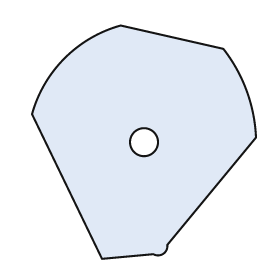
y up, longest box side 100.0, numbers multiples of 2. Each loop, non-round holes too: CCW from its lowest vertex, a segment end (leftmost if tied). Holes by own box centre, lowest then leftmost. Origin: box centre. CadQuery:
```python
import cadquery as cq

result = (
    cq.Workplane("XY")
    .moveTo(-18.0, -50.0)
    .lineTo(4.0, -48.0)
    .threePointArc((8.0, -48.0), (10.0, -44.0))
    .lineTo(48.0, 2.0)
    .threePointArc((44.0, 22.0), (34.0, 40.0))
    .lineTo(-10.0, 50.0)
    .threePointArc((-34.0, 36.0), (-48.0, 12.0))
    .close()
    .moveTo(0.0, 0.0)
    .circle(6.0)
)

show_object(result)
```